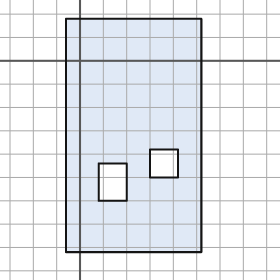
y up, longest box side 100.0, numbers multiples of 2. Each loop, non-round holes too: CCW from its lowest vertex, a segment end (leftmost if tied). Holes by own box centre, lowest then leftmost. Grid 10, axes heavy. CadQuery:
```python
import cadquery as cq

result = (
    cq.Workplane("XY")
    .moveTo(-6.0, -82.0)
    .lineTo(52.0, -82.0)
    .lineTo(52.0, 18.0)
    .lineTo(-6.0, 18.0)
    .close()
    .moveTo(8.0, -60.0)
    .lineTo(20.0, -60.0)
    .lineTo(20.0, -44.0)
    .lineTo(8.0, -44.0)
    .close()
    .moveTo(30.0, -50.0)
    .lineTo(42.0, -50.0)
    .lineTo(42.0, -38.0)
    .lineTo(30.0, -38.0)
    .close()
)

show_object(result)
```